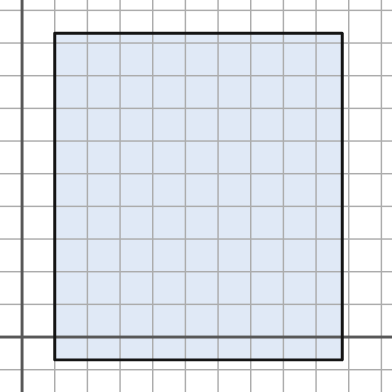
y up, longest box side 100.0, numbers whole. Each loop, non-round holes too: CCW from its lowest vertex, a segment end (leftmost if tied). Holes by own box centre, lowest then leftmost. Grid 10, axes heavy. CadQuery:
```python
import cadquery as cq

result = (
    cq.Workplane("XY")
    .moveTo(10.0, -7.0)
    .lineTo(98.0, -7.0)
    .lineTo(98.0, 93.0)
    .lineTo(10.0, 93.0)
    .close()
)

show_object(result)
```